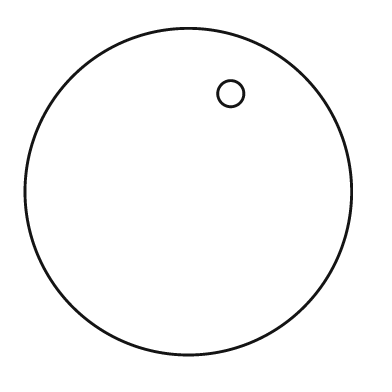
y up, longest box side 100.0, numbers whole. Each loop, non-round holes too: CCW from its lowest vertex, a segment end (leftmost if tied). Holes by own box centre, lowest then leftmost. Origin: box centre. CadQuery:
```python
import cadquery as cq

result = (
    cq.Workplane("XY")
    .moveTo(0.0, 0.0)
    .circle(50.0)
    .moveTo(13.0, 30.0)
    .circle(4.0)
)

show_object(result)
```